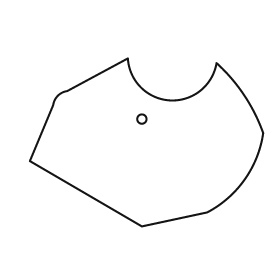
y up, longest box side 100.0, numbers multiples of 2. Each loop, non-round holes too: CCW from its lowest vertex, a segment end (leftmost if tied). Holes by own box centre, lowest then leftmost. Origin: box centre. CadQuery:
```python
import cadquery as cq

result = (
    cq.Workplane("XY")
    .moveTo(-2.0, -36.0)
    .lineTo(26.0, -30.0)
    .threePointArc((42.0, -16.0), (50.0, 4.0))
    .threePointArc((42.0, 20.0), (30.0, 34.0))
    .threePointArc((10.0, 18.0), (-8.0, 36.0))
    .lineTo(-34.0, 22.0)
    .threePointArc((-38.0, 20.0), (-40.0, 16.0))
    .lineTo(-50.0, -8.0)
    .close()
    .moveTo(-2.0, 10.0)
    .circle(2.0)
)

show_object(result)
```